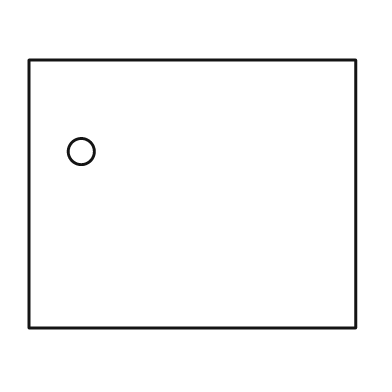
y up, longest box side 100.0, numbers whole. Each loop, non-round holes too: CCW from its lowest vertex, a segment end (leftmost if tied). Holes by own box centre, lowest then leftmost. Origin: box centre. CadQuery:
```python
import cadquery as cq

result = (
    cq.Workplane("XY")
    .moveTo(-50.0, -41.0)
    .lineTo(50.0, -41.0)
    .lineTo(50.0, 41.0)
    .lineTo(-50.0, 41.0)
    .close()
    .moveTo(-34.0, 13.0)
    .circle(4.0)
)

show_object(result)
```